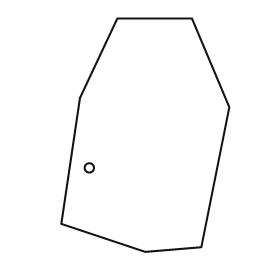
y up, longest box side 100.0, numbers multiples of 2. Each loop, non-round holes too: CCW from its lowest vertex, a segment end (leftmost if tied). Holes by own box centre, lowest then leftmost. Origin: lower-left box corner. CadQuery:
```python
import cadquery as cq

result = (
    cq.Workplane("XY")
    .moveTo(36.0, 0.0)
    .lineTo(60.0, 2.0)
    .lineTo(72.0, 62.0)
    .lineTo(56.0, 100.0)
    .lineTo(24.0, 100.0)
    .lineTo(8.0, 66.0)
    .lineTo(0.0, 12.0)
    .close()
    .moveTo(12.0, 36.0)
    .circle(2.0)
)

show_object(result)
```